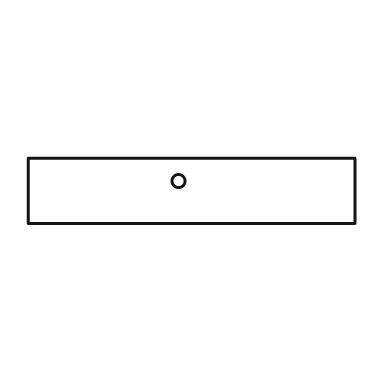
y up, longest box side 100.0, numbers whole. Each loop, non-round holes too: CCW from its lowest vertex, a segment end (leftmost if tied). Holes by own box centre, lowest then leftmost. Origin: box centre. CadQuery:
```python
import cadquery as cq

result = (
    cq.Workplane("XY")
    .moveTo(-50.0, -10.0)
    .lineTo(50.0, -10.0)
    .lineTo(50.0, 10.0)
    .lineTo(-50.0, 10.0)
    .close()
    .moveTo(-4.0, 3.0)
    .circle(2.0)
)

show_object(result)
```